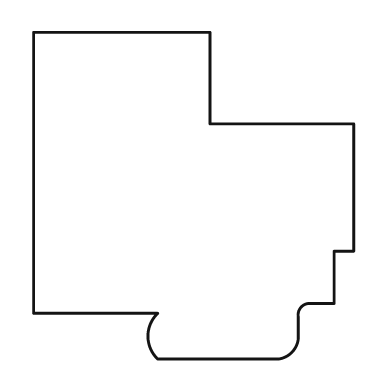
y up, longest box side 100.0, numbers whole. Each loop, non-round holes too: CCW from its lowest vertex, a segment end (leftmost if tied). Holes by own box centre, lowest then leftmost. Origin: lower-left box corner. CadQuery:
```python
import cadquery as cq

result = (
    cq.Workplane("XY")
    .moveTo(38.0, 0.0)
    .lineTo(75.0, 0.0)
    .threePointArc((79.0, 2.0), (81.0, 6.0))
    .lineTo(81.0, 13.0)
    .threePointArc((82.0, 16.0), (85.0, 17.0))
    .lineTo(92.0, 17.0)
    .lineTo(92.0, 33.0)
    .lineTo(98.0, 33.0)
    .lineTo(98.0, 72.0)
    .lineTo(54.0, 72.0)
    .lineTo(54.0, 100.0)
    .lineTo(0.0, 100.0)
    .lineTo(0.0, 14.0)
    .lineTo(38.0, 14.0)
    .threePointArc((35.0, 7.0), (38.0, 0.0))
    .close()
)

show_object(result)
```